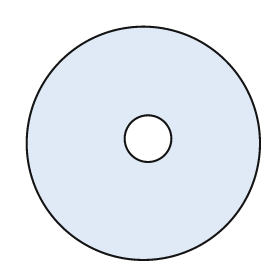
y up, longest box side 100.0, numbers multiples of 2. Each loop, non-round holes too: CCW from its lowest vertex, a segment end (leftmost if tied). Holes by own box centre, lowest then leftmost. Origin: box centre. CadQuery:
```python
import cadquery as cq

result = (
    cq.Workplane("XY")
    .moveTo(0.0, 0.0)
    .circle(50.0)
    .moveTo(2.0, 2.0)
    .circle(10.0)
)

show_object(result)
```